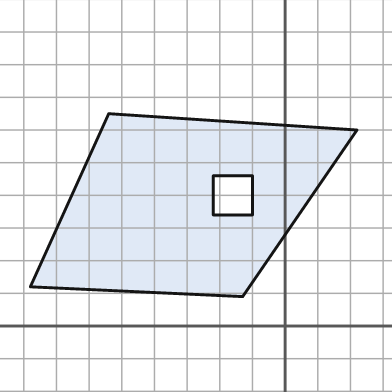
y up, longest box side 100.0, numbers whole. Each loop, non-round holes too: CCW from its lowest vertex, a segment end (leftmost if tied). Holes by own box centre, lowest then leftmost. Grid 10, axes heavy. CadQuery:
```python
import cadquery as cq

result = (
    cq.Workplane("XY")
    .moveTo(-13.0, 9.0)
    .lineTo(22.0, 60.0)
    .lineTo(-54.0, 65.0)
    .lineTo(-78.0, 12.0)
    .close()
    .moveTo(-22.0, 34.0)
    .lineTo(-10.0, 34.0)
    .lineTo(-10.0, 46.0)
    .lineTo(-22.0, 46.0)
    .close()
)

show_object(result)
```